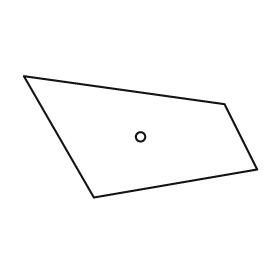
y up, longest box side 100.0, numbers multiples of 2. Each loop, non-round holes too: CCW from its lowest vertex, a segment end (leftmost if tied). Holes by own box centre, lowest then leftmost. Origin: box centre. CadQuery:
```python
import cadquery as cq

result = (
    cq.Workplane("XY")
    .moveTo(-20.0, -26.0)
    .lineTo(50.0, -14.0)
    .lineTo(36.0, 14.0)
    .lineTo(-50.0, 26.0)
    .close()
    .moveTo(0.0, 0.0)
    .circle(2.0)
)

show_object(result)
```